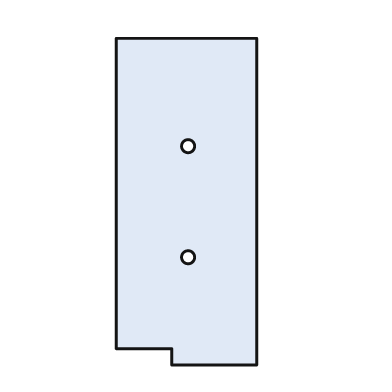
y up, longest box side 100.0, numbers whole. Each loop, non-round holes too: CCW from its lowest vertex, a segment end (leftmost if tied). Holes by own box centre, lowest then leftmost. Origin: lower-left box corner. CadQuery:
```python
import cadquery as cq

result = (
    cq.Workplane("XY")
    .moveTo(17.0, 0.0)
    .lineTo(43.0, 0.0)
    .lineTo(43.0, 100.0)
    .lineTo(0.0, 100.0)
    .lineTo(0.0, 5.0)
    .lineTo(17.0, 5.0)
    .close()
    .moveTo(22.0, 33.0)
    .circle(2.0)
    .moveTo(22.0, 67.0)
    .circle(2.0)
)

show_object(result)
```